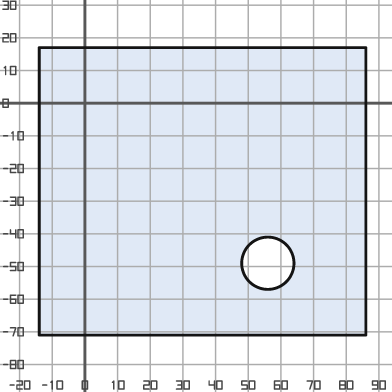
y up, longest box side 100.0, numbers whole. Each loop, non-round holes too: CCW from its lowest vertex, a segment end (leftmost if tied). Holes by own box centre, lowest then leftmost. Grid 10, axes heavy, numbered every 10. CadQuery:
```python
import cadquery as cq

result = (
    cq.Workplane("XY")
    .moveTo(-14.0, -71.0)
    .lineTo(86.0, -71.0)
    .lineTo(86.0, 17.0)
    .lineTo(-14.0, 17.0)
    .close()
    .moveTo(56.0, -49.0)
    .circle(8.0)
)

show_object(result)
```